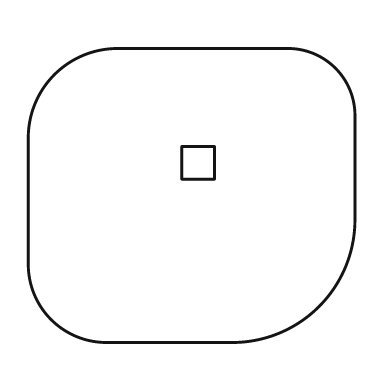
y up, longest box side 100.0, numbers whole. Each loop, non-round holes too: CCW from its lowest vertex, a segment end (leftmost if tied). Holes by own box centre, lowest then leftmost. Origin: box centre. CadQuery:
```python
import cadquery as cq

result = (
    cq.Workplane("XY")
    .moveTo(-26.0, -45.0)
    .lineTo(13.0, -45.0)
    .threePointArc((39.0, -34.0), (50.0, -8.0))
    .lineTo(50.0, 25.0)
    .threePointArc((44.0, 39.0), (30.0, 45.0))
    .lineTo(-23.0, 45.0)
    .threePointArc((-42.0, 37.0), (-50.0, 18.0))
    .lineTo(-50.0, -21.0)
    .threePointArc((-43.0, -38.0), (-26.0, -45.0))
    .close()
    .moveTo(-3.0, 5.0)
    .lineTo(7.0, 5.0)
    .lineTo(7.0, 15.0)
    .lineTo(-3.0, 15.0)
    .close()
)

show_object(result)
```